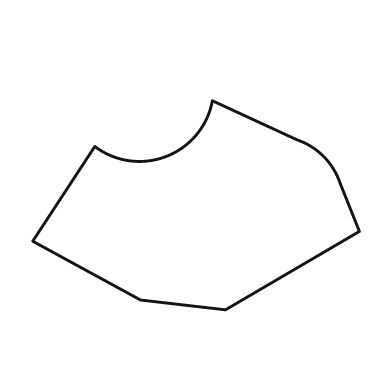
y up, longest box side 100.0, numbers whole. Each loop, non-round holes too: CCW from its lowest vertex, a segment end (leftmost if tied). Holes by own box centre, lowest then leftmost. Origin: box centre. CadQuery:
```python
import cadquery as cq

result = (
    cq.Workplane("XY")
    .moveTo(9.0, -32.0)
    .lineTo(50.0, -8.0)
    .lineTo(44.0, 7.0)
    .threePointArc((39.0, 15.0), (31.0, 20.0))
    .lineTo(5.0, 32.0)
    .threePointArc((-9.0, 15.0), (-31.0, 18.0))
    .lineTo(-50.0, -11.0)
    .lineTo(-17.0, -29.0)
    .close()
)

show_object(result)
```